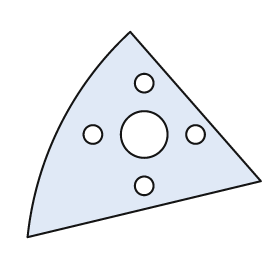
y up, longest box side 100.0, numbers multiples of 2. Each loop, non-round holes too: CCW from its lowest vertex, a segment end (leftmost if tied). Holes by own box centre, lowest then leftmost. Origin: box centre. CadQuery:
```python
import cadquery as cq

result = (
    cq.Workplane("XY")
    .moveTo(-50.0, -44.0)
    .lineTo(50.0, -20.0)
    .lineTo(-6.0, 44.0)
    .threePointArc((-36.0, 4.0), (-50.0, -44.0))
    .close()
    .moveTo(0.0, -22.0)
    .circle(4.0)
    .moveTo(-22.0, 0.0)
    .circle(4.0)
    .moveTo(0.0, 0.0)
    .circle(10.0)
    .moveTo(22.0, 0.0)
    .circle(4.0)
    .moveTo(0.0, 22.0)
    .circle(4.0)
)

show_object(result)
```